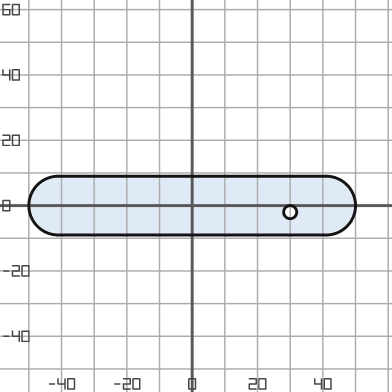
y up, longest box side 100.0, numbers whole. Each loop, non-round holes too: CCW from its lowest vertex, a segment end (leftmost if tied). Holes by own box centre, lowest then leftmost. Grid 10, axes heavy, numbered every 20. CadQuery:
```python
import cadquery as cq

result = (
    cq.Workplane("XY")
    .moveTo(-41.0, -9.0)
    .lineTo(41.0, -9.0)
    .threePointArc((50.0, 0.0), (41.0, 9.0))
    .lineTo(-41.0, 9.0)
    .threePointArc((-50.0, 0.0), (-41.0, -9.0))
    .close()
    .moveTo(30.0, -2.0)
    .circle(2.0)
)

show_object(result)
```